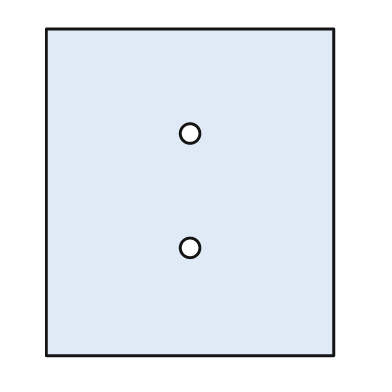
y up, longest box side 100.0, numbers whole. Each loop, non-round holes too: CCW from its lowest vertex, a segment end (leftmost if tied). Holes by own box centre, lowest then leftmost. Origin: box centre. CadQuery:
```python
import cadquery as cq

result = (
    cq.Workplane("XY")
    .moveTo(-44.0, -50.0)
    .lineTo(44.0, -50.0)
    .lineTo(44.0, 50.0)
    .lineTo(-44.0, 50.0)
    .close()
    .moveTo(0.0, -17.0)
    .circle(3.0)
    .moveTo(0.0, 18.0)
    .circle(3.0)
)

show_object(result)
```